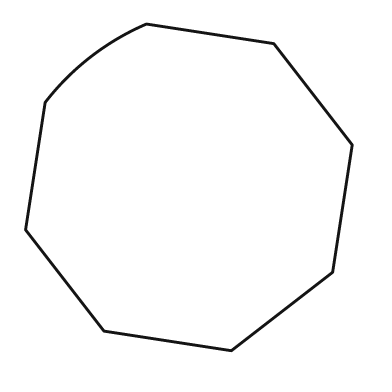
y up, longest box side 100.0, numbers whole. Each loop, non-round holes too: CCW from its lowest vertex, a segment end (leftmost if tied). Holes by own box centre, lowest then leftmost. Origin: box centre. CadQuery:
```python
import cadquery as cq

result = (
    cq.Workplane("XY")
    .moveTo(13.0, -50.0)
    .lineTo(44.0, -26.0)
    .lineTo(50.0, 13.0)
    .lineTo(26.0, 44.0)
    .lineTo(-13.0, 50.0)
    .threePointArc((-30.0, 40.0), (-44.0, 26.0))
    .lineTo(-50.0, -13.0)
    .lineTo(-26.0, -44.0)
    .close()
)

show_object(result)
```